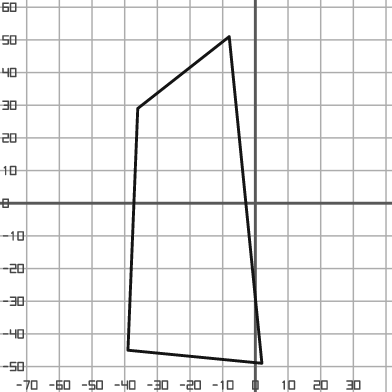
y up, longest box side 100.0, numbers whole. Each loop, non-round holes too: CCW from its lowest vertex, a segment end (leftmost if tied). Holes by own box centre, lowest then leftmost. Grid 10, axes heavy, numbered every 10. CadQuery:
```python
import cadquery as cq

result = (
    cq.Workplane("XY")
    .moveTo(2.0, -49.0)
    .lineTo(-8.0, 51.0)
    .lineTo(-36.0, 29.0)
    .lineTo(-39.0, -45.0)
    .close()
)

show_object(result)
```